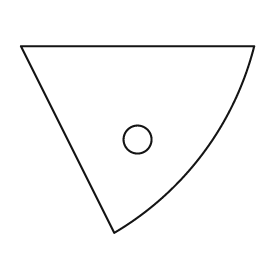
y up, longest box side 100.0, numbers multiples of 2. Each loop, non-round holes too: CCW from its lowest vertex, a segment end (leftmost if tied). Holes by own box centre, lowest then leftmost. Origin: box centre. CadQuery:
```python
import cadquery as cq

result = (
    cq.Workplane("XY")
    .moveTo(-10.0, -40.0)
    .threePointArc((28.0, -6.0), (50.0, 40.0))
    .lineTo(-50.0, 40.0)
    .close()
    .moveTo(0.0, 0.0)
    .circle(6.0)
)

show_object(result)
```